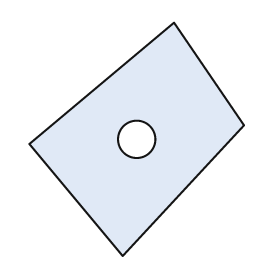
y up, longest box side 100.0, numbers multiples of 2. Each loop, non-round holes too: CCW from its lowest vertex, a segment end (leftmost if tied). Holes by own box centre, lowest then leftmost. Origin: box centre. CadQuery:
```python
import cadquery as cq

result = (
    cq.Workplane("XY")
    .moveTo(-6.0, -50.0)
    .lineTo(46.0, 6.0)
    .lineTo(16.0, 50.0)
    .lineTo(-46.0, -2.0)
    .close()
    .moveTo(0.0, 0.0)
    .circle(8.0)
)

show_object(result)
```